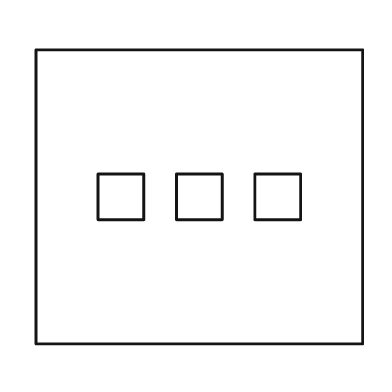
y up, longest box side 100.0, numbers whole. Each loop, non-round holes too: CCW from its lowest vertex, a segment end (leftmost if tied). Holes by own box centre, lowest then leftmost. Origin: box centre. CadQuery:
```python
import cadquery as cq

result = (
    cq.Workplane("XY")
    .moveTo(-50.0, -45.0)
    .lineTo(50.0, -45.0)
    .lineTo(50.0, 45.0)
    .lineTo(-50.0, 45.0)
    .close()
    .moveTo(-31.0, -7.0)
    .lineTo(-17.0, -7.0)
    .lineTo(-17.0, 7.0)
    .lineTo(-31.0, 7.0)
    .close()
    .moveTo(-7.0, -7.0)
    .lineTo(7.0, -7.0)
    .lineTo(7.0, 7.0)
    .lineTo(-7.0, 7.0)
    .close()
    .moveTo(17.0, -7.0)
    .lineTo(31.0, -7.0)
    .lineTo(31.0, 7.0)
    .lineTo(17.0, 7.0)
    .close()
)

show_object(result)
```